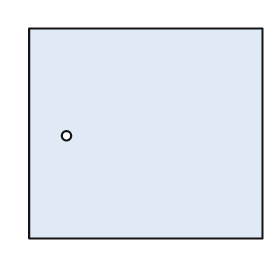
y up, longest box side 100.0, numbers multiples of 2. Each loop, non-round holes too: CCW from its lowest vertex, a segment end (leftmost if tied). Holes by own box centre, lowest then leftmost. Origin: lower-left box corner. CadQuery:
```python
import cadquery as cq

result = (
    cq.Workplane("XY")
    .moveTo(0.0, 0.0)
    .lineTo(100.0, 0.0)
    .lineTo(100.0, 90.0)
    .lineTo(0.0, 90.0)
    .close()
    .moveTo(16.0, 44.0)
    .circle(2.0)
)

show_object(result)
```